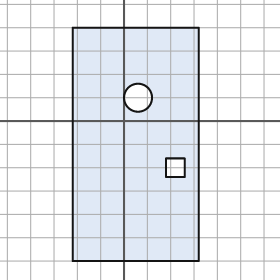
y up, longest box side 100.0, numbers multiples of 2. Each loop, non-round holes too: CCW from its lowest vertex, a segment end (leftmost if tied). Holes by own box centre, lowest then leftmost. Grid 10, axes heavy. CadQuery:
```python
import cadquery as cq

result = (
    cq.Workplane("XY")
    .moveTo(-22.0, -60.0)
    .lineTo(32.0, -60.0)
    .lineTo(32.0, 40.0)
    .lineTo(-22.0, 40.0)
    .close()
    .moveTo(18.0, -24.0)
    .lineTo(26.0, -24.0)
    .lineTo(26.0, -16.0)
    .lineTo(18.0, -16.0)
    .close()
    .moveTo(6.0, 10.0)
    .circle(6.0)
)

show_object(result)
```